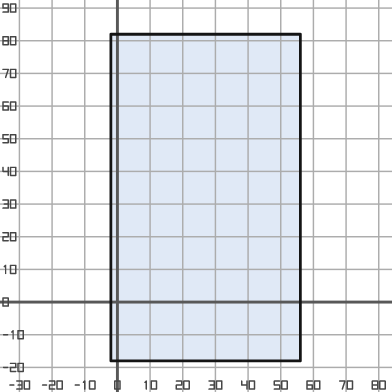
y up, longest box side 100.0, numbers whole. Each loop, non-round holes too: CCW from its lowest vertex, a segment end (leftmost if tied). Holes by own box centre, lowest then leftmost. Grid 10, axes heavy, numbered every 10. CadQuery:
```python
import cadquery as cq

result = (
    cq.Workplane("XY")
    .moveTo(-2.0, -18.0)
    .lineTo(56.0, -18.0)
    .lineTo(56.0, 82.0)
    .lineTo(-2.0, 82.0)
    .close()
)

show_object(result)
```